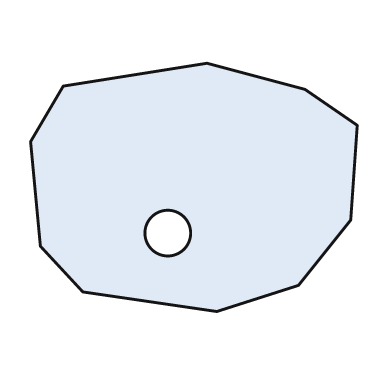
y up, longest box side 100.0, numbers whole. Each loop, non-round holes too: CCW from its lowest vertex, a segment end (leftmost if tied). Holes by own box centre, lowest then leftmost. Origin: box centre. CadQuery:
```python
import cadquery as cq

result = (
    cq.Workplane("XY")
    .moveTo(7.0, -38.0)
    .lineTo(32.0, -30.0)
    .lineTo(48.0, -10.0)
    .lineTo(50.0, 19.0)
    .lineTo(34.0, 30.0)
    .lineTo(4.0, 38.0)
    .lineTo(-40.0, 31.0)
    .lineTo(-50.0, 14.0)
    .lineTo(-47.0, -18.0)
    .lineTo(-34.0, -32.0)
    .close()
    .moveTo(-8.0, -14.0)
    .circle(7.0)
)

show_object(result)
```